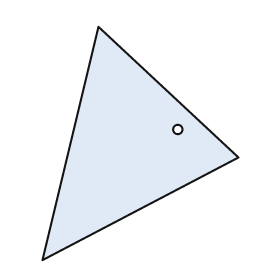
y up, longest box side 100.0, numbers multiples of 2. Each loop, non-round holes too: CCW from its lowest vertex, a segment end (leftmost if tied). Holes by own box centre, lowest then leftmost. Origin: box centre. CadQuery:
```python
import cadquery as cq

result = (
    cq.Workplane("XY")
    .moveTo(-42.0, -50.0)
    .lineTo(42.0, -6.0)
    .lineTo(-18.0, 50.0)
    .close()
    .moveTo(16.0, 6.0)
    .circle(2.0)
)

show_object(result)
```